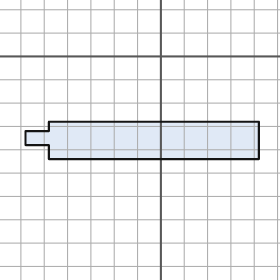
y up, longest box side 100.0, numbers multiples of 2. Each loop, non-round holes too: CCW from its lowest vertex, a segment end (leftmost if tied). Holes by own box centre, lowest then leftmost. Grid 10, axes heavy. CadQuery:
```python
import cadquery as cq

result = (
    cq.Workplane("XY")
    .moveTo(-48.0, -44.0)
    .lineTo(42.0, -44.0)
    .lineTo(42.0, -28.0)
    .lineTo(-48.0, -28.0)
    .lineTo(-48.0, -32.0)
    .lineTo(-58.0, -32.0)
    .lineTo(-58.0, -38.0)
    .lineTo(-48.0, -38.0)
    .close()
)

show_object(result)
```